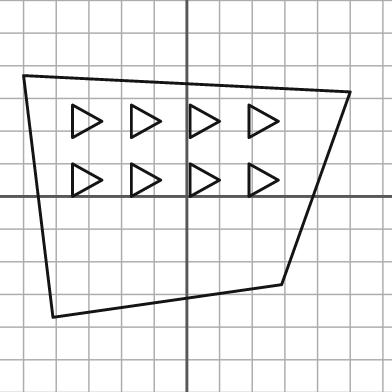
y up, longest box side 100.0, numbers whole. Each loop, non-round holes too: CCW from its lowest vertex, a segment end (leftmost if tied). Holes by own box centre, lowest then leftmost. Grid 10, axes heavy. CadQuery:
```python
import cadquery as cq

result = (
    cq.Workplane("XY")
    .moveTo(-41.0, -37.0)
    .lineTo(29.0, -27.0)
    .lineTo(50.0, 32.0)
    .lineTo(-50.0, 37.0)
    .close()
    .moveTo(-35.0, 0.0)
    .lineTo(-26.0, 5.0)
    .lineTo(-35.0, 10.0)
    .close()
    .moveTo(-17.0, 0.0)
    .lineTo(-8.0, 5.0)
    .lineTo(-17.0, 10.0)
    .close()
    .moveTo(1.0, 0.0)
    .lineTo(10.0, 5.0)
    .lineTo(1.0, 10.0)
    .close()
    .moveTo(19.0, 0.0)
    .lineTo(28.0, 5.0)
    .lineTo(19.0, 10.0)
    .close()
    .moveTo(-35.0, 18.0)
    .lineTo(-26.0, 23.0)
    .lineTo(-35.0, 28.0)
    .close()
    .moveTo(-17.0, 18.0)
    .lineTo(-8.0, 23.0)
    .lineTo(-17.0, 28.0)
    .close()
    .moveTo(1.0, 18.0)
    .lineTo(10.0, 23.0)
    .lineTo(1.0, 28.0)
    .close()
    .moveTo(19.0, 18.0)
    .lineTo(28.0, 23.0)
    .lineTo(19.0, 28.0)
    .close()
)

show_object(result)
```